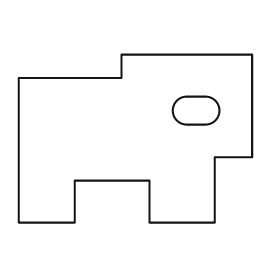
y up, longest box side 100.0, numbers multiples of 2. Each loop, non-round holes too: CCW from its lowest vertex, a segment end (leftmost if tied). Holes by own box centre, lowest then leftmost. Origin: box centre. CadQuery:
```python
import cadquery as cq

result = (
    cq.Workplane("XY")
    .moveTo(-50.0, -36.0)
    .lineTo(-26.0, -36.0)
    .lineTo(-26.0, -18.0)
    .lineTo(6.0, -18.0)
    .lineTo(6.0, -36.0)
    .lineTo(34.0, -36.0)
    .lineTo(34.0, -8.0)
    .lineTo(50.0, -8.0)
    .lineTo(50.0, 36.0)
    .lineTo(-6.0, 36.0)
    .lineTo(-6.0, 26.0)
    .lineTo(-50.0, 26.0)
    .close()
    .moveTo(22.0, 6.0)
    .lineTo(30.0, 6.0)
    .threePointArc((36.0, 12.0), (30.0, 18.0))
    .lineTo(22.0, 18.0)
    .threePointArc((16.0, 12.0), (22.0, 6.0))
    .close()
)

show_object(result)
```